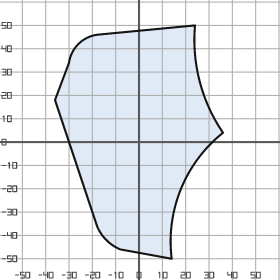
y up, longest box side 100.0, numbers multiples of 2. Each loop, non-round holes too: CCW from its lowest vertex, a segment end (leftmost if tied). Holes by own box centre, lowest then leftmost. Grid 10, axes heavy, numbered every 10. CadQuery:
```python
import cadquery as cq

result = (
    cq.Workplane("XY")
    .moveTo(14.0, -50.0)
    .threePointArc((18.0, -20.0), (36.0, 4.0))
    .threePointArc((26.0, 26.0), (24.0, 50.0))
    .lineTo(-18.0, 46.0)
    .threePointArc((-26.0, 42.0), (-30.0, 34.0))
    .lineTo(-36.0, 18.0)
    .lineTo(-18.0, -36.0)
    .threePointArc((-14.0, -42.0), (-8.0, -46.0))
    .close()
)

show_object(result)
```